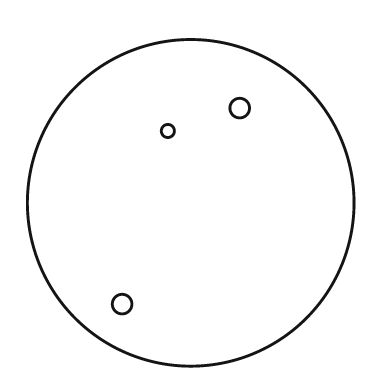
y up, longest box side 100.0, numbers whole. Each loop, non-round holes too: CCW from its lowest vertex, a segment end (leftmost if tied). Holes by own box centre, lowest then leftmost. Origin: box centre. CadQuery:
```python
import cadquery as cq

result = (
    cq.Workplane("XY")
    .moveTo(0.0, 0.0)
    .circle(50.0)
    .moveTo(-21.0, -31.0)
    .circle(3.0)
    .moveTo(-7.0, 22.0)
    .circle(2.0)
    .moveTo(15.0, 29.0)
    .circle(3.0)
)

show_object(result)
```